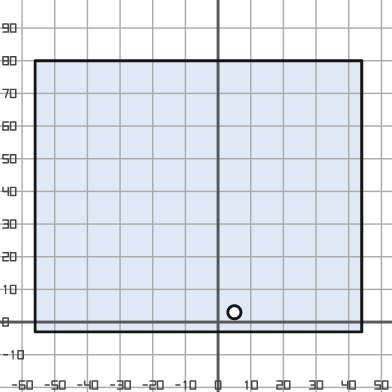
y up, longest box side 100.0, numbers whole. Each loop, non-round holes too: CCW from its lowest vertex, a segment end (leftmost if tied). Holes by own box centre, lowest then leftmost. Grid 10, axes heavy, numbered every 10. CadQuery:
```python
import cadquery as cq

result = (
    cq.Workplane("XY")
    .moveTo(-56.0, -3.0)
    .lineTo(44.0, -3.0)
    .lineTo(44.0, 80.0)
    .lineTo(-56.0, 80.0)
    .close()
    .moveTo(5.0, 3.0)
    .circle(2.0)
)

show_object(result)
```